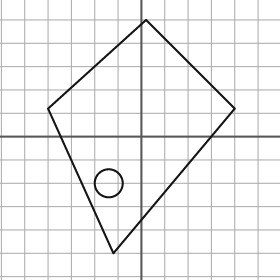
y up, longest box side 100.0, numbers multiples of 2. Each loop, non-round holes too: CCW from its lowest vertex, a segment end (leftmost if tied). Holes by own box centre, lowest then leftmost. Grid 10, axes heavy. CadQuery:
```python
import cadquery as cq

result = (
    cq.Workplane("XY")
    .moveTo(-12.0, -50.0)
    .lineTo(40.0, 12.0)
    .lineTo(2.0, 50.0)
    .lineTo(-40.0, 12.0)
    .close()
    .moveTo(-14.0, -20.0)
    .circle(6.0)
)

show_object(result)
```